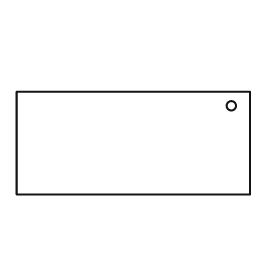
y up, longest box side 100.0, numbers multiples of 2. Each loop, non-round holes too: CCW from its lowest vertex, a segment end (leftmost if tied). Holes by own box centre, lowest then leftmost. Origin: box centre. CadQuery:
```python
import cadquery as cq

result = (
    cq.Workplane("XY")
    .moveTo(-50.0, -22.0)
    .lineTo(50.0, -22.0)
    .lineTo(50.0, 22.0)
    .lineTo(-50.0, 22.0)
    .close()
    .moveTo(42.0, 16.0)
    .circle(2.0)
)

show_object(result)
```